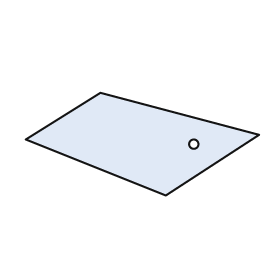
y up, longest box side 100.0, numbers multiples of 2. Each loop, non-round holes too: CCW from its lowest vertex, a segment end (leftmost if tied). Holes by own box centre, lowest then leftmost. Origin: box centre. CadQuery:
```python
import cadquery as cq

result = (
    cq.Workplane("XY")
    .moveTo(10.0, -22.0)
    .lineTo(50.0, 4.0)
    .lineTo(-18.0, 22.0)
    .lineTo(-50.0, 2.0)
    .close()
    .moveTo(22.0, 0.0)
    .circle(2.0)
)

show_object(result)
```